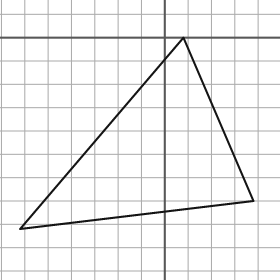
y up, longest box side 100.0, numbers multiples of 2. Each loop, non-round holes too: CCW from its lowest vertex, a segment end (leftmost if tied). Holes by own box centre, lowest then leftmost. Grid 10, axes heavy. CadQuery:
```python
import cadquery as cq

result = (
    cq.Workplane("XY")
    .moveTo(-62.0, -82.0)
    .lineTo(38.0, -70.0)
    .lineTo(8.0, 0.0)
    .close()
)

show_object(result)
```